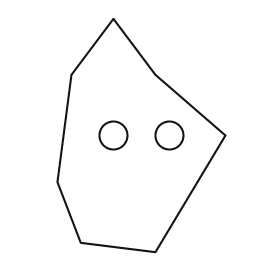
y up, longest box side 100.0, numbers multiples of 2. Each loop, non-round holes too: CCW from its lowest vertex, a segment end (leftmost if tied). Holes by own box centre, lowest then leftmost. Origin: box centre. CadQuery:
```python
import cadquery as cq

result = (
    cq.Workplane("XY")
    .moveTo(6.0, -50.0)
    .lineTo(36.0, 0.0)
    .lineTo(6.0, 26.0)
    .lineTo(-12.0, 50.0)
    .lineTo(-30.0, 26.0)
    .lineTo(-36.0, -20.0)
    .lineTo(-26.0, -46.0)
    .close()
    .moveTo(-12.0, 0.0)
    .circle(6.0)
    .moveTo(12.0, 0.0)
    .circle(6.0)
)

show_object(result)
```